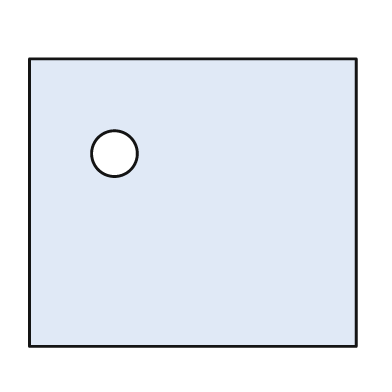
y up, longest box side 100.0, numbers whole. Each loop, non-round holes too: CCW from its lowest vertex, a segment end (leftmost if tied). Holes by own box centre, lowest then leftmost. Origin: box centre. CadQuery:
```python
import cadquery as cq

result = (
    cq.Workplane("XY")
    .moveTo(-50.0, -44.0)
    .lineTo(50.0, -44.0)
    .lineTo(50.0, 44.0)
    .lineTo(-50.0, 44.0)
    .close()
    .moveTo(-24.0, 15.0)
    .circle(7.0)
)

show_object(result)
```